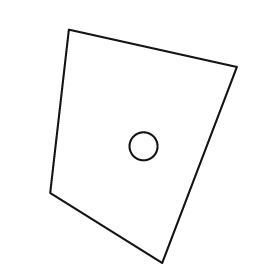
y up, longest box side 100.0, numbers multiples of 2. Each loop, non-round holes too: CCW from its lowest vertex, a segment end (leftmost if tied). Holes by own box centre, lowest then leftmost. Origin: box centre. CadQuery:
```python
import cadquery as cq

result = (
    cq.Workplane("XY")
    .moveTo(8.0, -50.0)
    .lineTo(40.0, 34.0)
    .lineTo(-32.0, 50.0)
    .lineTo(-40.0, -20.0)
    .close()
    .moveTo(0.0, 0.0)
    .circle(6.0)
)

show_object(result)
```